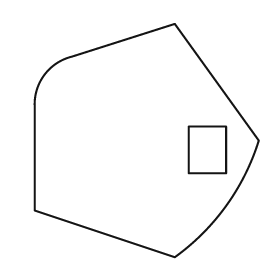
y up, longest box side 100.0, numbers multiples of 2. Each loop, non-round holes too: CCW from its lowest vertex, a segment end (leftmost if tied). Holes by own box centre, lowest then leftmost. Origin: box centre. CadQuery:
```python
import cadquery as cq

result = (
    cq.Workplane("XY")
    .moveTo(12.0, -50.0)
    .threePointArc((34.0, -28.0), (48.0, 0.0))
    .lineTo(12.0, 50.0)
    .lineTo(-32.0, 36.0)
    .threePointArc((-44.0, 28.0), (-48.0, 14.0))
    .lineTo(-48.0, -30.0)
    .close()
    .moveTo(18.0, -14.0)
    .lineTo(34.0, -14.0)
    .lineTo(34.0, 6.0)
    .lineTo(18.0, 6.0)
    .close()
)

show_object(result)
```